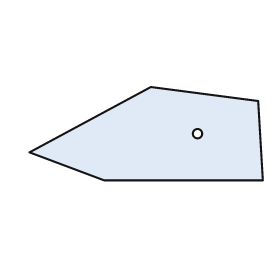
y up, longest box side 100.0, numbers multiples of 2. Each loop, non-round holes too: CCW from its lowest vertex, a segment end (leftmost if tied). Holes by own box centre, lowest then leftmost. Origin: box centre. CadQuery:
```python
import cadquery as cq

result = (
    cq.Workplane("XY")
    .moveTo(-18.0, -20.0)
    .lineTo(50.0, -20.0)
    .lineTo(48.0, 14.0)
    .lineTo(2.0, 20.0)
    .lineTo(-50.0, -8.0)
    .close()
    .moveTo(22.0, 0.0)
    .circle(2.0)
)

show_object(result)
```